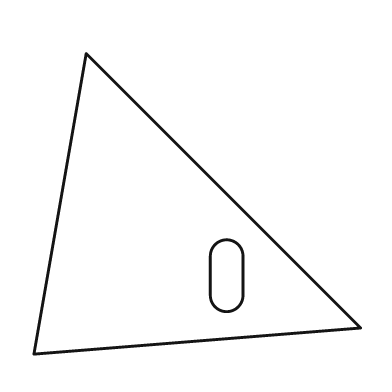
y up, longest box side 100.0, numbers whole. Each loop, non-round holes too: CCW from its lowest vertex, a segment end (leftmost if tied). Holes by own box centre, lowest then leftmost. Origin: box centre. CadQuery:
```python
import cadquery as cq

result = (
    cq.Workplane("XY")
    .moveTo(-50.0, -46.0)
    .lineTo(50.0, -38.0)
    .lineTo(-34.0, 46.0)
    .close()
    .moveTo(4.0, -28.0)
    .threePointArc((9.0, -33.0), (14.0, -28.0))
    .lineTo(14.0, -16.0)
    .threePointArc((9.0, -11.0), (4.0, -16.0))
    .close()
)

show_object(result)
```